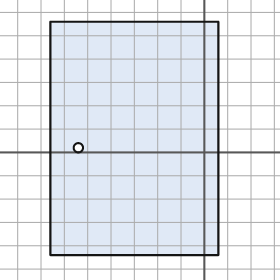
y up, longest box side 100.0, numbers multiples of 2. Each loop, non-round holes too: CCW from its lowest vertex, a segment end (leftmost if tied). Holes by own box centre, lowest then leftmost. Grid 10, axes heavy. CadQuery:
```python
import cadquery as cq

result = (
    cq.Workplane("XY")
    .moveTo(-66.0, -44.0)
    .lineTo(6.0, -44.0)
    .lineTo(6.0, 56.0)
    .lineTo(-66.0, 56.0)
    .close()
    .moveTo(-54.0, 2.0)
    .circle(2.0)
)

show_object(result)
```